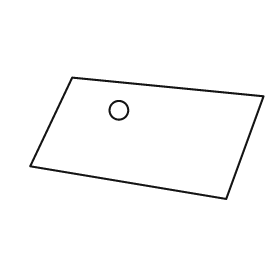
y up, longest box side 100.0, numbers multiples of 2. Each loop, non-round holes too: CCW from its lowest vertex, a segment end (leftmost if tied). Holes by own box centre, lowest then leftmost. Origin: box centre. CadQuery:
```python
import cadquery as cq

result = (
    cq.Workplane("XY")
    .moveTo(34.0, -26.0)
    .lineTo(50.0, 18.0)
    .lineTo(-32.0, 26.0)
    .lineTo(-50.0, -12.0)
    .close()
    .moveTo(-12.0, 12.0)
    .circle(4.0)
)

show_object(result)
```